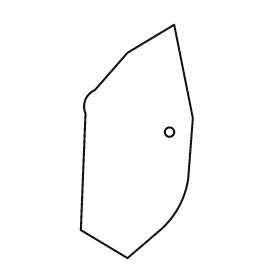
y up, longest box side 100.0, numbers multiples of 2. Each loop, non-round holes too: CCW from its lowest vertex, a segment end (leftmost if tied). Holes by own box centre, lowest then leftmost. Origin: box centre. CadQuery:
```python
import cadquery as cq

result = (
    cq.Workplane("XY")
    .moveTo(-4.0, -50.0)
    .lineTo(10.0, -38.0)
    .threePointArc((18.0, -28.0), (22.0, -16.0))
    .lineTo(24.0, 10.0)
    .lineTo(16.0, 50.0)
    .lineTo(-4.0, 38.0)
    .lineTo(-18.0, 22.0)
    .threePointArc((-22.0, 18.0), (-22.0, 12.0))
    .lineTo(-24.0, -38.0)
    .close()
    .moveTo(14.0, 4.0)
    .circle(2.0)
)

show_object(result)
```